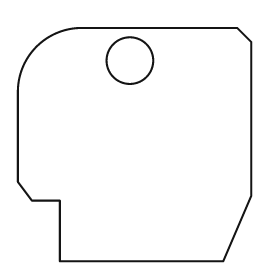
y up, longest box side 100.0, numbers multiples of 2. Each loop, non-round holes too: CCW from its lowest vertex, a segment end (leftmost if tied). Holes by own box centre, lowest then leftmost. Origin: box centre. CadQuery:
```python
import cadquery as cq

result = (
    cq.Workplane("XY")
    .moveTo(-32.0, -50.0)
    .lineTo(38.0, -50.0)
    .lineTo(50.0, -22.0)
    .lineTo(50.0, 44.0)
    .lineTo(44.0, 50.0)
    .lineTo(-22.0, 50.0)
    .threePointArc((-42.0, 42.0), (-50.0, 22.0))
    .lineTo(-50.0, -16.0)
    .lineTo(-44.0, -24.0)
    .lineTo(-32.0, -24.0)
    .close()
    .moveTo(-2.0, 36.0)
    .circle(10.0)
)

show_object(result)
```